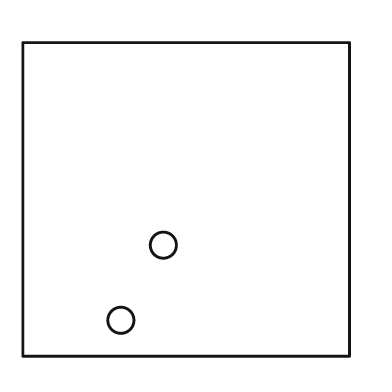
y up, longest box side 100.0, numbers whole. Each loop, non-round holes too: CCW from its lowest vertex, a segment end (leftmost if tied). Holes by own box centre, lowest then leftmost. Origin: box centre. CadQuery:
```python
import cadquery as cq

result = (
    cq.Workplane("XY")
    .moveTo(-50.0, -48.0)
    .lineTo(50.0, -48.0)
    .lineTo(50.0, 48.0)
    .lineTo(-50.0, 48.0)
    .close()
    .moveTo(-20.0, -37.0)
    .circle(4.0)
    .moveTo(-7.0, -14.0)
    .circle(4.0)
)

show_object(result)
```